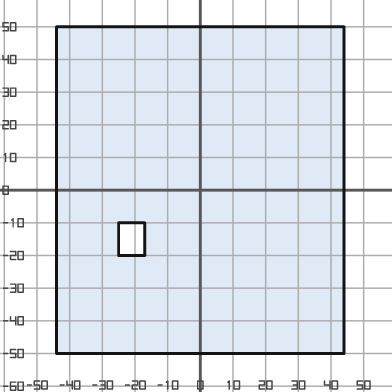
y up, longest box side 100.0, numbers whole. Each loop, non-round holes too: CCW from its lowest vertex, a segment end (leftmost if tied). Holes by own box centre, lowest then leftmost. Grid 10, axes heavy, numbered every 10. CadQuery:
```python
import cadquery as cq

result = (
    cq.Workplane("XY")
    .moveTo(-44.0, -50.0)
    .lineTo(44.0, -50.0)
    .lineTo(44.0, 50.0)
    .lineTo(-44.0, 50.0)
    .close()
    .moveTo(-25.0, -20.0)
    .lineTo(-17.0, -20.0)
    .lineTo(-17.0, -10.0)
    .lineTo(-25.0, -10.0)
    .close()
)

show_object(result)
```